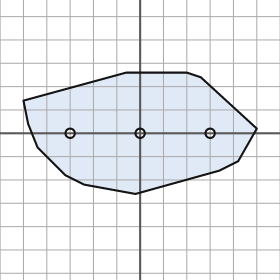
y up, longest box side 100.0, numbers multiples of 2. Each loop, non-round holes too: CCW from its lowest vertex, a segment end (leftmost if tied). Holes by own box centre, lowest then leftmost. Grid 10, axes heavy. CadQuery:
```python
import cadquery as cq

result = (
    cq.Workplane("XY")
    .moveTo(-2.0, -26.0)
    .lineTo(34.0, -16.0)
    .lineTo(42.0, -12.0)
    .lineTo(50.0, 2.0)
    .lineTo(26.0, 24.0)
    .lineTo(20.0, 26.0)
    .lineTo(-6.0, 26.0)
    .lineTo(-50.0, 14.0)
    .lineTo(-48.0, 4.0)
    .lineTo(-44.0, -6.0)
    .lineTo(-32.0, -18.0)
    .lineTo(-24.0, -22.0)
    .close()
    .moveTo(-30.0, 0.0)
    .circle(2.0)
    .moveTo(0.0, 0.0)
    .circle(2.0)
    .moveTo(30.0, 0.0)
    .circle(2.0)
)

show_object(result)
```